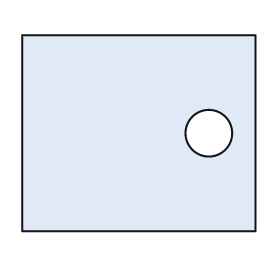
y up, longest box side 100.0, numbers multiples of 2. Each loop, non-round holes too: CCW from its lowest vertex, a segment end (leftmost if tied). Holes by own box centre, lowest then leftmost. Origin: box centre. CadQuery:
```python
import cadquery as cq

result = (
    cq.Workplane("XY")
    .moveTo(-50.0, -42.0)
    .lineTo(50.0, -42.0)
    .lineTo(50.0, 42.0)
    .lineTo(-50.0, 42.0)
    .close()
    .moveTo(30.0, 0.0)
    .circle(10.0)
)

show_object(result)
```